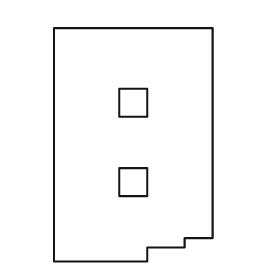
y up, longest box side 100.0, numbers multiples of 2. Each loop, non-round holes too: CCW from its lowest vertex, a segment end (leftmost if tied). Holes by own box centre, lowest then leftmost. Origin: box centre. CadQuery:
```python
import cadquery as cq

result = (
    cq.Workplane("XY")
    .moveTo(-34.0, -50.0)
    .lineTo(6.0, -50.0)
    .lineTo(6.0, -44.0)
    .lineTo(22.0, -44.0)
    .lineTo(22.0, -40.0)
    .lineTo(34.0, -40.0)
    .lineTo(34.0, 50.0)
    .lineTo(-34.0, 50.0)
    .close()
    .moveTo(-6.0, -22.0)
    .lineTo(6.0, -22.0)
    .lineTo(6.0, -10.0)
    .lineTo(-6.0, -10.0)
    .close()
    .moveTo(-6.0, 12.0)
    .lineTo(6.0, 12.0)
    .lineTo(6.0, 24.0)
    .lineTo(-6.0, 24.0)
    .close()
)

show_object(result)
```